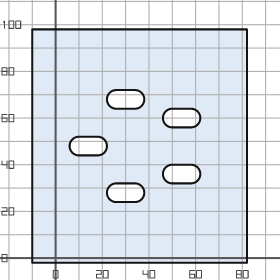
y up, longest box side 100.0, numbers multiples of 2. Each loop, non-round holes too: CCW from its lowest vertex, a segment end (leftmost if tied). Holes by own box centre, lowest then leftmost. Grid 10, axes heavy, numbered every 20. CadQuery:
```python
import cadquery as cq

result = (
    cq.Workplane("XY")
    .moveTo(-10.0, -2.0)
    .lineTo(82.0, -2.0)
    .lineTo(82.0, 98.0)
    .lineTo(-10.0, 98.0)
    .close()
    .moveTo(26.0, 24.0)
    .lineTo(34.0, 24.0)
    .threePointArc((38.0, 28.0), (34.0, 32.0))
    .lineTo(26.0, 32.0)
    .threePointArc((22.0, 28.0), (26.0, 24.0))
    .close()
    .moveTo(50.0, 32.0)
    .lineTo(58.0, 32.0)
    .threePointArc((62.0, 36.0), (58.0, 40.0))
    .lineTo(50.0, 40.0)
    .threePointArc((46.0, 36.0), (50.0, 32.0))
    .close()
    .moveTo(10.0, 44.0)
    .lineTo(18.0, 44.0)
    .threePointArc((22.0, 48.0), (18.0, 52.0))
    .lineTo(10.0, 52.0)
    .threePointArc((6.0, 48.0), (10.0, 44.0))
    .close()
    .moveTo(50.0, 56.0)
    .lineTo(58.0, 56.0)
    .threePointArc((62.0, 60.0), (58.0, 64.0))
    .lineTo(50.0, 64.0)
    .threePointArc((46.0, 60.0), (50.0, 56.0))
    .close()
    .moveTo(26.0, 64.0)
    .lineTo(34.0, 64.0)
    .threePointArc((38.0, 68.0), (34.0, 72.0))
    .lineTo(26.0, 72.0)
    .threePointArc((22.0, 68.0), (26.0, 64.0))
    .close()
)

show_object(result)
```